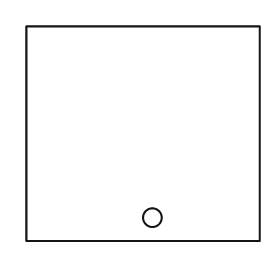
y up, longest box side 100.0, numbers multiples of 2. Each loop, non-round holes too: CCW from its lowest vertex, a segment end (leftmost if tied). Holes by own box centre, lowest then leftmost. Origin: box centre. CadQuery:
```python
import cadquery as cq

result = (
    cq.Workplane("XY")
    .moveTo(-50.0, -46.0)
    .lineTo(50.0, -46.0)
    .lineTo(50.0, 46.0)
    .lineTo(-50.0, 46.0)
    .close()
    .moveTo(4.0, -36.0)
    .circle(4.0)
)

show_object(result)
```